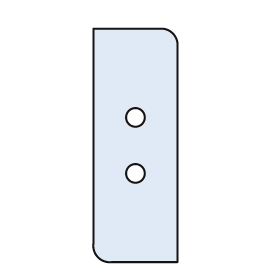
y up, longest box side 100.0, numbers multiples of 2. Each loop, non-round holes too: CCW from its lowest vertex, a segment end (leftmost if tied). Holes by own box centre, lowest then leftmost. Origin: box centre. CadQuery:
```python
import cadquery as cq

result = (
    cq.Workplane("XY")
    .moveTo(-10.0, -50.0)
    .lineTo(18.0, -50.0)
    .lineTo(18.0, 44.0)
    .threePointArc((16.0, 48.0), (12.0, 50.0))
    .lineTo(-18.0, 50.0)
    .lineTo(-18.0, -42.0)
    .threePointArc((-16.0, -48.0), (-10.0, -50.0))
    .close()
    .moveTo(0.0, -12.0)
    .circle(4.0)
    .moveTo(0.0, 12.0)
    .circle(4.0)
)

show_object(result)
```